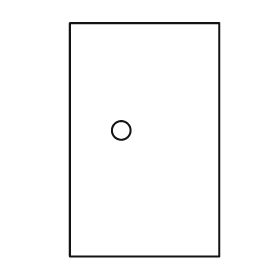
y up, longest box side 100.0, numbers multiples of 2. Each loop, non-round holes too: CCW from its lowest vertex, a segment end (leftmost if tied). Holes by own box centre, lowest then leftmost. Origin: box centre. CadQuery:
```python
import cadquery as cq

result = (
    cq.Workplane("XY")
    .moveTo(-32.0, -50.0)
    .lineTo(32.0, -50.0)
    .lineTo(32.0, 50.0)
    .lineTo(-32.0, 50.0)
    .close()
    .moveTo(-10.0, 4.0)
    .circle(4.0)
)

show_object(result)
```